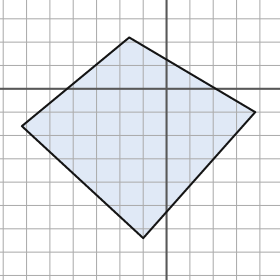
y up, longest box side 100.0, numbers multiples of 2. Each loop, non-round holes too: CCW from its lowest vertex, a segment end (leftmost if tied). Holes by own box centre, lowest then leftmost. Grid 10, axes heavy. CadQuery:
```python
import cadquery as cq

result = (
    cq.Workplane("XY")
    .moveTo(-10.0, -64.0)
    .lineTo(38.0, -10.0)
    .lineTo(-16.0, 22.0)
    .lineTo(-62.0, -16.0)
    .close()
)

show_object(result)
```